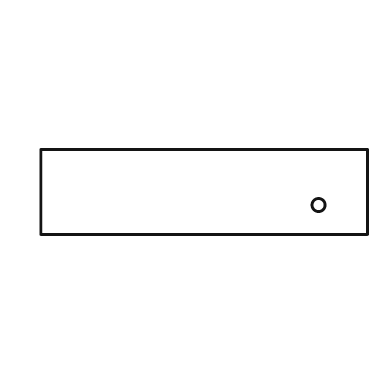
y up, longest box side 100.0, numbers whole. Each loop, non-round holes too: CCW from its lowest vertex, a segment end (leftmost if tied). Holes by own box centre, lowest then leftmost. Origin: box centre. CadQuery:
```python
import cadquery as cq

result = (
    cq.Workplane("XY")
    .moveTo(-50.0, -13.0)
    .lineTo(50.0, -13.0)
    .lineTo(50.0, 13.0)
    .lineTo(-50.0, 13.0)
    .close()
    .moveTo(35.0, -4.0)
    .circle(2.0)
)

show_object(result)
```